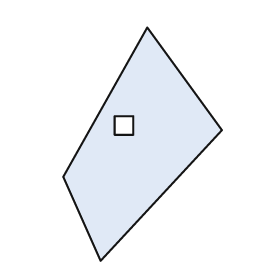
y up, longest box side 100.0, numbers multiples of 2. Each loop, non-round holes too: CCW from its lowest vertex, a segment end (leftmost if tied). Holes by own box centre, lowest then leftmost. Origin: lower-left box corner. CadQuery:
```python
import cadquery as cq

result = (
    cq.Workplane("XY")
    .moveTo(16.0, 0.0)
    .lineTo(68.0, 56.0)
    .lineTo(36.0, 100.0)
    .lineTo(0.0, 36.0)
    .close()
    .moveTo(22.0, 54.0)
    .lineTo(30.0, 54.0)
    .lineTo(30.0, 62.0)
    .lineTo(22.0, 62.0)
    .close()
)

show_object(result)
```